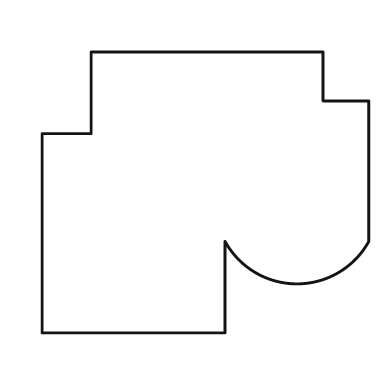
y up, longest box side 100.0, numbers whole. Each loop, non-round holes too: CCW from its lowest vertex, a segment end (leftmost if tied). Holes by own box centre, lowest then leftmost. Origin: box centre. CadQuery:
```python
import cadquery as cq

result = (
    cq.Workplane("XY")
    .moveTo(-50.0, -43.0)
    .lineTo(6.0, -43.0)
    .lineTo(6.0, -15.0)
    .threePointArc((28.0, -28.0), (50.0, -15.0))
    .lineTo(50.0, 28.0)
    .lineTo(36.0, 28.0)
    .lineTo(36.0, 43.0)
    .lineTo(-35.0, 43.0)
    .lineTo(-35.0, 18.0)
    .lineTo(-50.0, 18.0)
    .close()
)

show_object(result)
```